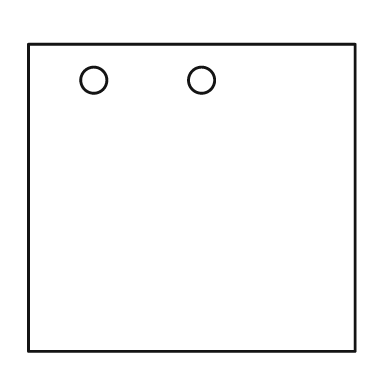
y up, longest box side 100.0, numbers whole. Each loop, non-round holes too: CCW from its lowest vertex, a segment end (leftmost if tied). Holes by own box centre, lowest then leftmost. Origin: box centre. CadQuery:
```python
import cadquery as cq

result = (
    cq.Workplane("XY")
    .moveTo(-50.0, -47.0)
    .lineTo(50.0, -47.0)
    .lineTo(50.0, 47.0)
    .lineTo(-50.0, 47.0)
    .close()
    .moveTo(-30.0, 36.0)
    .circle(4.0)
    .moveTo(3.0, 36.0)
    .circle(4.0)
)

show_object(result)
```